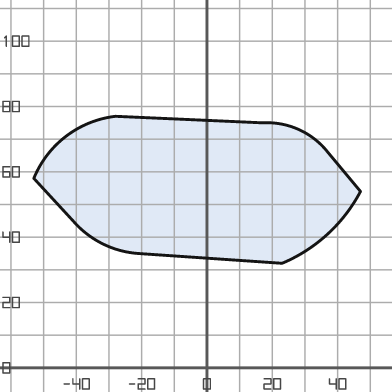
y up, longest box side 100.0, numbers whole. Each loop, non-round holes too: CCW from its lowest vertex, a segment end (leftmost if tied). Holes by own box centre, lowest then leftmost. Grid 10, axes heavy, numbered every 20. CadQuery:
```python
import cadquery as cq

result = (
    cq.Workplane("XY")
    .moveTo(23.0, 32.0)
    .threePointArc((37.0, 41.0), (47.0, 54.0))
    .lineTo(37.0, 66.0)
    .threePointArc((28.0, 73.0), (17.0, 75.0))
    .lineTo(-28.0, 77.0)
    .threePointArc((-43.0, 71.0), (-53.0, 58.0))
    .lineTo(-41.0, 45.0)
    .threePointArc((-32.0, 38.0), (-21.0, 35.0))
    .close()
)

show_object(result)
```